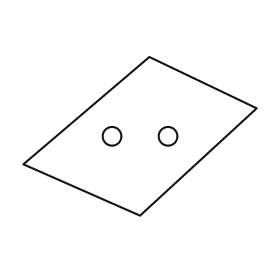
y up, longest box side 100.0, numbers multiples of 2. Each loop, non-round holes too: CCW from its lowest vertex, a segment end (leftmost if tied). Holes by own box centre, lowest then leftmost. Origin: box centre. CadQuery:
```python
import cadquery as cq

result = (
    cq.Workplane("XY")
    .moveTo(0.0, -34.0)
    .lineTo(50.0, 12.0)
    .lineTo(4.0, 34.0)
    .lineTo(-50.0, -12.0)
    .close()
    .moveTo(-12.0, 0.0)
    .circle(4.0)
    .moveTo(12.0, 0.0)
    .circle(4.0)
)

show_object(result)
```